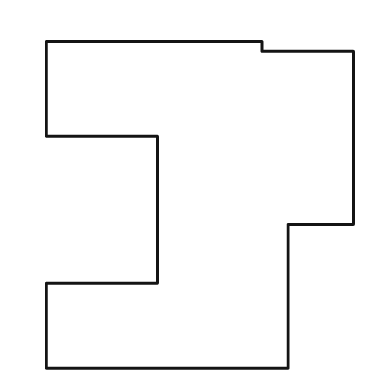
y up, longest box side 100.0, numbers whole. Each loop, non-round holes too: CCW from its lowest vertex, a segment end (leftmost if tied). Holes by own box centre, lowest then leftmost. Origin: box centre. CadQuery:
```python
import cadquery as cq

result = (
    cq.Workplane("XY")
    .moveTo(-47.0, -50.0)
    .lineTo(27.0, -50.0)
    .lineTo(27.0, -6.0)
    .lineTo(47.0, -6.0)
    .lineTo(47.0, 47.0)
    .lineTo(19.0, 47.0)
    .lineTo(19.0, 50.0)
    .lineTo(-47.0, 50.0)
    .lineTo(-47.0, 21.0)
    .lineTo(-13.0, 21.0)
    .lineTo(-13.0, -24.0)
    .lineTo(-47.0, -24.0)
    .close()
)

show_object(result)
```